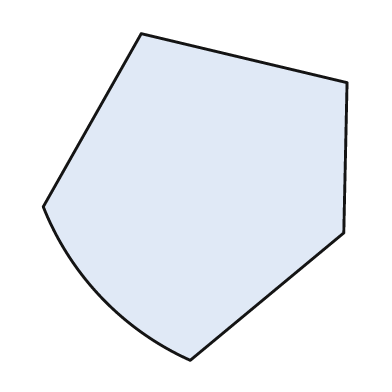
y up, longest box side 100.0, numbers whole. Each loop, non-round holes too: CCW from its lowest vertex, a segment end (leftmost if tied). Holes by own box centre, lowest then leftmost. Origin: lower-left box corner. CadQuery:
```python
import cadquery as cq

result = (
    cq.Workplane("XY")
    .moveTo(45.0, 0.0)
    .lineTo(92.0, 39.0)
    .lineTo(93.0, 85.0)
    .lineTo(30.0, 100.0)
    .lineTo(0.0, 47.0)
    .threePointArc((18.0, 19.0), (45.0, 0.0))
    .close()
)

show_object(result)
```